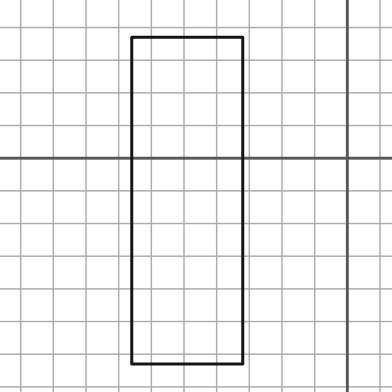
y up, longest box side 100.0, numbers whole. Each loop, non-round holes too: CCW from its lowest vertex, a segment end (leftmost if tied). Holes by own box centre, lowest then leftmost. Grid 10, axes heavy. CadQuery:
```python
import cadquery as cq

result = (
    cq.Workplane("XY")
    .moveTo(-66.0, -63.0)
    .lineTo(-32.0, -63.0)
    .lineTo(-32.0, 37.0)
    .lineTo(-66.0, 37.0)
    .close()
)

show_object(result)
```